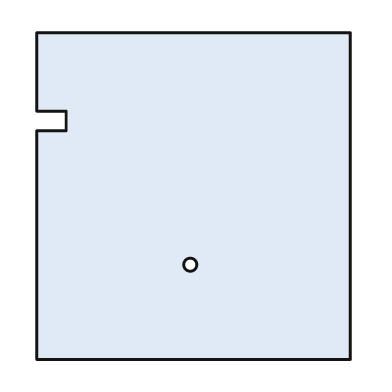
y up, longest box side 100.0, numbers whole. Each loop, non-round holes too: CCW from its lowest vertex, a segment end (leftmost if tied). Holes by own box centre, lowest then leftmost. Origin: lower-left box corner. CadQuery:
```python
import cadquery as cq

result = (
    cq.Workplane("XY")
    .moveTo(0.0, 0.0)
    .lineTo(96.0, 0.0)
    .lineTo(96.0, 100.0)
    .lineTo(0.0, 100.0)
    .lineTo(0.0, 76.0)
    .lineTo(9.0, 76.0)
    .lineTo(9.0, 70.0)
    .lineTo(0.0, 70.0)
    .close()
    .moveTo(47.0, 29.0)
    .circle(2.0)
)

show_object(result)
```